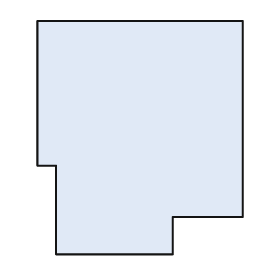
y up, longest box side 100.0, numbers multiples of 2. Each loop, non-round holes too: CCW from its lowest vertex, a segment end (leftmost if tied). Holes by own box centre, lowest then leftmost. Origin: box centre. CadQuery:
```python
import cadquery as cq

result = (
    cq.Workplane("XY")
    .moveTo(-36.0, -50.0)
    .lineTo(14.0, -50.0)
    .lineTo(14.0, -34.0)
    .lineTo(44.0, -34.0)
    .lineTo(44.0, 50.0)
    .lineTo(-44.0, 50.0)
    .lineTo(-44.0, -12.0)
    .lineTo(-36.0, -12.0)
    .close()
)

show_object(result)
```